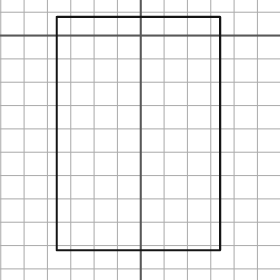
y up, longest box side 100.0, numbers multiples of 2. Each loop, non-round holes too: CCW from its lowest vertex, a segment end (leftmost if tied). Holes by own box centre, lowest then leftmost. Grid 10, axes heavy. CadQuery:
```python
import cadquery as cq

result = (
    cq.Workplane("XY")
    .moveTo(-36.0, -92.0)
    .lineTo(34.0, -92.0)
    .lineTo(34.0, 8.0)
    .lineTo(-36.0, 8.0)
    .close()
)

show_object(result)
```